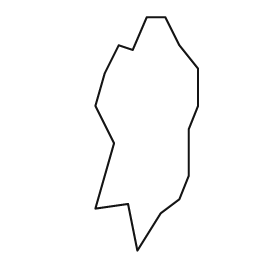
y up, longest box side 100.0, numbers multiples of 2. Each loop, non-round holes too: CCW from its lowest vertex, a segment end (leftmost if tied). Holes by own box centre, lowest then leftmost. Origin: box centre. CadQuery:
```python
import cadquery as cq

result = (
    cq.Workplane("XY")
    .moveTo(-4.0, -50.0)
    .lineTo(6.0, -34.0)
    .lineTo(14.0, -28.0)
    .lineTo(18.0, -18.0)
    .lineTo(18.0, 2.0)
    .lineTo(22.0, 12.0)
    .lineTo(22.0, 28.0)
    .lineTo(14.0, 38.0)
    .lineTo(8.0, 50.0)
    .lineTo(0.0, 50.0)
    .lineTo(-6.0, 36.0)
    .lineTo(-12.0, 38.0)
    .lineTo(-18.0, 26.0)
    .lineTo(-22.0, 12.0)
    .lineTo(-14.0, -4.0)
    .lineTo(-22.0, -32.0)
    .lineTo(-8.0, -30.0)
    .close()
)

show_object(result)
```